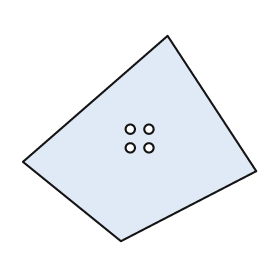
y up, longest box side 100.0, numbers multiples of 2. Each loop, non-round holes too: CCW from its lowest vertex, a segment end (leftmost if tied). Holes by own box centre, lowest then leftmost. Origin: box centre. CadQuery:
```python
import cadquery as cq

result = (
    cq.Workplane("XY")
    .moveTo(-8.0, -44.0)
    .lineTo(50.0, -14.0)
    .lineTo(12.0, 44.0)
    .lineTo(-50.0, -10.0)
    .close()
    .moveTo(-4.0, -4.0)
    .circle(2.0)
    .moveTo(4.0, -4.0)
    .circle(2.0)
    .moveTo(-4.0, 4.0)
    .circle(2.0)
    .moveTo(4.0, 4.0)
    .circle(2.0)
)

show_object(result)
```